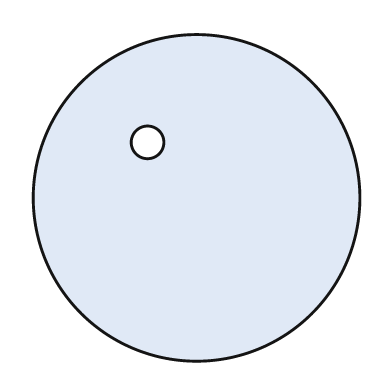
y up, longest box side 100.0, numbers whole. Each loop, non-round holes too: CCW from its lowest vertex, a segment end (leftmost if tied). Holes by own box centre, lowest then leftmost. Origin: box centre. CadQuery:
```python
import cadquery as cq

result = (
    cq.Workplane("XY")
    .moveTo(0.0, 0.0)
    .circle(50.0)
    .moveTo(-15.0, 17.0)
    .circle(5.0)
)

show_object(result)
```